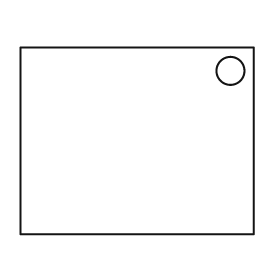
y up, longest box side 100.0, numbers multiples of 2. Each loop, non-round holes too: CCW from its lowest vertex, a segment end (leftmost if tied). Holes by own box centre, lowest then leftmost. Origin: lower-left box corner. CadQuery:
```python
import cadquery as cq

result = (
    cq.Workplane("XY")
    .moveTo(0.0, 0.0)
    .lineTo(100.0, 0.0)
    .lineTo(100.0, 80.0)
    .lineTo(0.0, 80.0)
    .close()
    .moveTo(90.0, 70.0)
    .circle(6.0)
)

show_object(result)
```